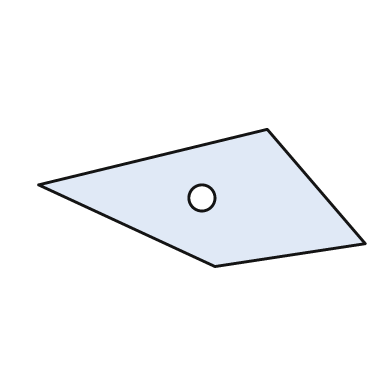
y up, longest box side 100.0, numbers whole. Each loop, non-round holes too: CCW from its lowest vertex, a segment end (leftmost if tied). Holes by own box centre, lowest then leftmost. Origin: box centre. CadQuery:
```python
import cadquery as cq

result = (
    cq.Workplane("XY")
    .moveTo(4.0, -21.0)
    .lineTo(50.0, -14.0)
    .lineTo(20.0, 21.0)
    .lineTo(-50.0, 4.0)
    .close()
    .moveTo(0.0, 0.0)
    .circle(4.0)
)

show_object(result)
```